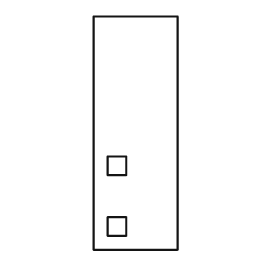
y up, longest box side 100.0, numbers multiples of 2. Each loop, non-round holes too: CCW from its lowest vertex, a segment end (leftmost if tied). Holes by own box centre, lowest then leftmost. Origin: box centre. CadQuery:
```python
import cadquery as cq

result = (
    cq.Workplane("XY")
    .moveTo(-18.0, -50.0)
    .lineTo(18.0, -50.0)
    .lineTo(18.0, 50.0)
    .lineTo(-18.0, 50.0)
    .close()
    .moveTo(-12.0, -44.0)
    .lineTo(-4.0, -44.0)
    .lineTo(-4.0, -36.0)
    .lineTo(-12.0, -36.0)
    .close()
    .moveTo(-12.0, -18.0)
    .lineTo(-4.0, -18.0)
    .lineTo(-4.0, -10.0)
    .lineTo(-12.0, -10.0)
    .close()
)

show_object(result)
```